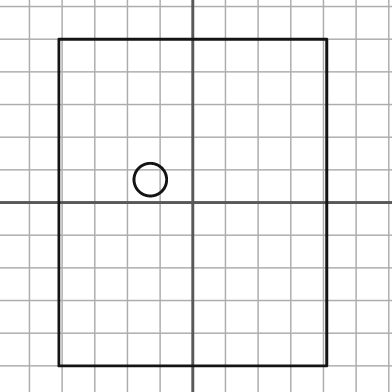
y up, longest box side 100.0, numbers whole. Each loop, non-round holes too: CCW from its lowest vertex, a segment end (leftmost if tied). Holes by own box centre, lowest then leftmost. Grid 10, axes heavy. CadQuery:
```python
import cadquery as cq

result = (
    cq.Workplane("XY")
    .moveTo(-41.0, -50.0)
    .lineTo(41.0, -50.0)
    .lineTo(41.0, 50.0)
    .lineTo(-41.0, 50.0)
    .close()
    .moveTo(-13.0, 7.0)
    .circle(5.0)
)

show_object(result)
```